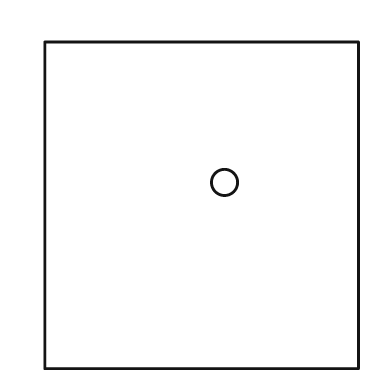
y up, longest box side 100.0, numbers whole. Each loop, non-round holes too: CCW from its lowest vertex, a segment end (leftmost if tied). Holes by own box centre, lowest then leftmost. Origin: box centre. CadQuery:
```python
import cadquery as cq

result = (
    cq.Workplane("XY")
    .moveTo(-48.0, -50.0)
    .lineTo(48.0, -50.0)
    .lineTo(48.0, 50.0)
    .lineTo(-48.0, 50.0)
    .close()
    .moveTo(7.0, 7.0)
    .circle(4.0)
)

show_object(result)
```